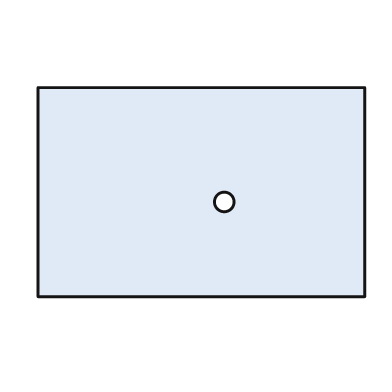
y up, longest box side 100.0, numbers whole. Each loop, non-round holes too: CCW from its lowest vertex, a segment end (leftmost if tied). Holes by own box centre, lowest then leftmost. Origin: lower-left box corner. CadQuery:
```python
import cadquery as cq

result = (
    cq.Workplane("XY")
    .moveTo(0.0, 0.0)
    .lineTo(100.0, 0.0)
    .lineTo(100.0, 64.0)
    .lineTo(0.0, 64.0)
    .close()
    .moveTo(57.0, 29.0)
    .circle(3.0)
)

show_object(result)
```